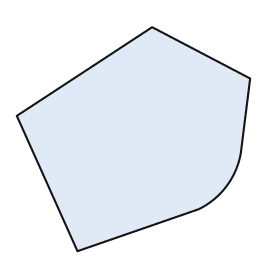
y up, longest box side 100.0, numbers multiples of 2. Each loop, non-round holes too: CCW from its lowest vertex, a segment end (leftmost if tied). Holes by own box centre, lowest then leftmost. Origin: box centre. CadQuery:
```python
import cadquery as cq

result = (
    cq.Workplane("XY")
    .moveTo(-24.0, -48.0)
    .lineTo(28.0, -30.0)
    .threePointArc((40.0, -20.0), (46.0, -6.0))
    .lineTo(50.0, 26.0)
    .lineTo(8.0, 48.0)
    .lineTo(-50.0, 10.0)
    .close()
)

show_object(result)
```